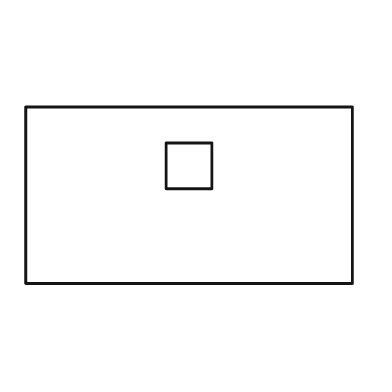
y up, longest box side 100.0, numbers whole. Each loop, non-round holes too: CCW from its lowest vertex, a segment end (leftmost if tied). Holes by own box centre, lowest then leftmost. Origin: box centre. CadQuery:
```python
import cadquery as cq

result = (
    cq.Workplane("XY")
    .moveTo(-50.0, -27.0)
    .lineTo(50.0, -27.0)
    .lineTo(50.0, 27.0)
    .lineTo(-50.0, 27.0)
    .close()
    .moveTo(-7.0, 2.0)
    .lineTo(7.0, 2.0)
    .lineTo(7.0, 16.0)
    .lineTo(-7.0, 16.0)
    .close()
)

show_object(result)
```